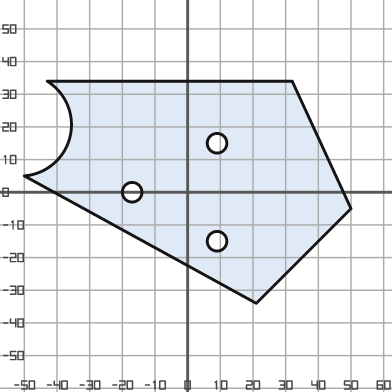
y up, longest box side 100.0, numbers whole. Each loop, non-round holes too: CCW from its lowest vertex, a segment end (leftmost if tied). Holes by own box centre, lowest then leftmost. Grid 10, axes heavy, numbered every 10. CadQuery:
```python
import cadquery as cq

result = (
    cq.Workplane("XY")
    .moveTo(21.0, -34.0)
    .lineTo(50.0, -5.0)
    .lineTo(32.0, 34.0)
    .lineTo(-43.0, 34.0)
    .threePointArc((-36.0, 17.0), (-50.0, 5.0))
    .close()
    .moveTo(9.0, -15.0)
    .circle(3.0)
    .moveTo(-17.0, 0.0)
    .circle(3.0)
    .moveTo(9.0, 15.0)
    .circle(3.0)
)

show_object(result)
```